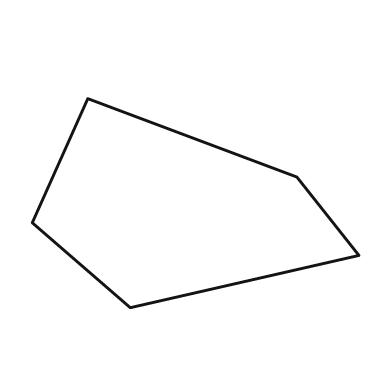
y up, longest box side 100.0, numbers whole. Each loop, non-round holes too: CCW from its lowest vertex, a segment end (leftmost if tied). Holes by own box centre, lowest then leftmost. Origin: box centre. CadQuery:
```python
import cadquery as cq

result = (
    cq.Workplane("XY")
    .moveTo(-20.0, -32.0)
    .lineTo(50.0, -16.0)
    .lineTo(31.0, 8.0)
    .lineTo(-33.0, 32.0)
    .lineTo(-50.0, -6.0)
    .close()
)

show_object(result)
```